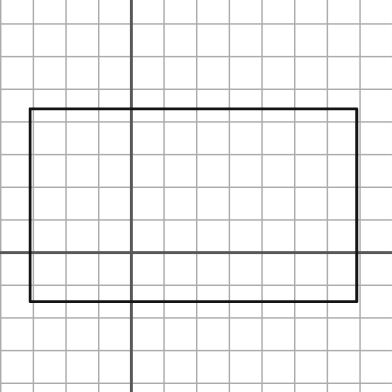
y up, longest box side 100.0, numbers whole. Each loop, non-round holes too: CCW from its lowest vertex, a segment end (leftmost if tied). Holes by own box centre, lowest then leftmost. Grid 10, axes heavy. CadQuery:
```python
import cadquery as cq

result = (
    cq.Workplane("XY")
    .moveTo(-31.0, -15.0)
    .lineTo(69.0, -15.0)
    .lineTo(69.0, 44.0)
    .lineTo(-31.0, 44.0)
    .close()
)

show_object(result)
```